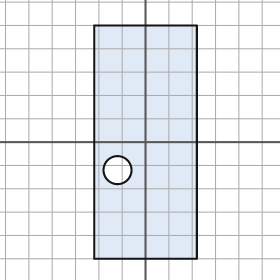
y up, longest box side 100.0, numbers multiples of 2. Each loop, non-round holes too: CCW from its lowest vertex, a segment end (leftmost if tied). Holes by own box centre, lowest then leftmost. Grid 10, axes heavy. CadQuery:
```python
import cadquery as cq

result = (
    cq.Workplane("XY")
    .moveTo(-22.0, -50.0)
    .lineTo(22.0, -50.0)
    .lineTo(22.0, 50.0)
    .lineTo(-22.0, 50.0)
    .close()
    .moveTo(-12.0, -12.0)
    .circle(6.0)
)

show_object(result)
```